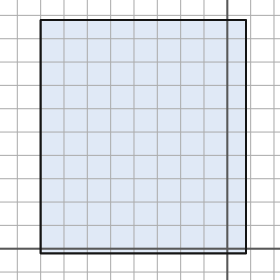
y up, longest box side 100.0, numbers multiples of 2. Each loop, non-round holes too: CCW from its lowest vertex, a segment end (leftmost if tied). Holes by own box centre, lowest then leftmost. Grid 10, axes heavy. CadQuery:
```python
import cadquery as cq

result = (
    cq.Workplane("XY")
    .moveTo(-80.0, -2.0)
    .lineTo(8.0, -2.0)
    .lineTo(8.0, 98.0)
    .lineTo(-80.0, 98.0)
    .close()
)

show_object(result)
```